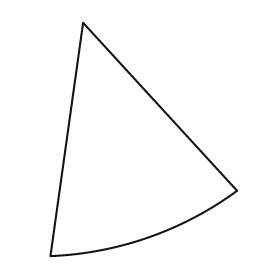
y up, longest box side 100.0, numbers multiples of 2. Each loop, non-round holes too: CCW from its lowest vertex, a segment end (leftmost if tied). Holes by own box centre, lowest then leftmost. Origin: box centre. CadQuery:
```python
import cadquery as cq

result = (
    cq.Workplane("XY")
    .moveTo(-40.0, -50.0)
    .threePointArc((2.0, -42.0), (40.0, -22.0))
    .lineTo(-26.0, 50.0)
    .close()
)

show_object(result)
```